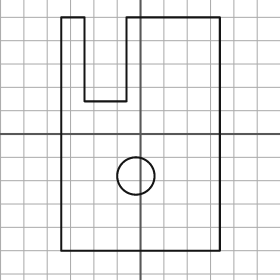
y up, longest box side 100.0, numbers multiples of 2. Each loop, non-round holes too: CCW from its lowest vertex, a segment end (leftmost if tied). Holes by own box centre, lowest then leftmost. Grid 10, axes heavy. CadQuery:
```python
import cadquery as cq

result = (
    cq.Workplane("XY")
    .moveTo(-34.0, -50.0)
    .lineTo(34.0, -50.0)
    .lineTo(34.0, 50.0)
    .lineTo(-6.0, 50.0)
    .lineTo(-6.0, 14.0)
    .lineTo(-24.0, 14.0)
    .lineTo(-24.0, 50.0)
    .lineTo(-34.0, 50.0)
    .close()
    .moveTo(-2.0, -18.0)
    .circle(8.0)
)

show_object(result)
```